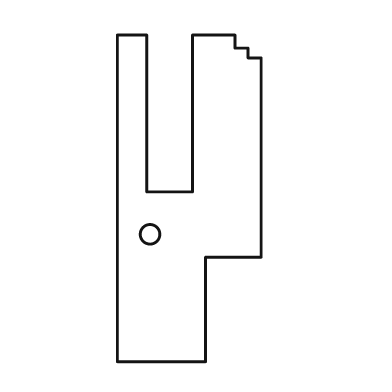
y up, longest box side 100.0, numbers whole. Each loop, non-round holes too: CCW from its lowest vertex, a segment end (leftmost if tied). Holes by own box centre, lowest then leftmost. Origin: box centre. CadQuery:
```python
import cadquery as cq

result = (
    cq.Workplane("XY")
    .moveTo(-22.0, -50.0)
    .lineTo(5.0, -50.0)
    .lineTo(5.0, -18.0)
    .lineTo(22.0, -18.0)
    .lineTo(22.0, 43.0)
    .lineTo(18.0, 43.0)
    .lineTo(18.0, 46.0)
    .lineTo(14.0, 46.0)
    .lineTo(14.0, 50.0)
    .lineTo(1.0, 50.0)
    .lineTo(1.0, 2.0)
    .lineTo(-13.0, 2.0)
    .lineTo(-13.0, 50.0)
    .lineTo(-22.0, 50.0)
    .close()
    .moveTo(-12.0, -11.0)
    .circle(3.0)
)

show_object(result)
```